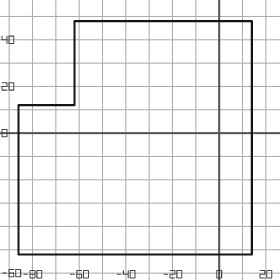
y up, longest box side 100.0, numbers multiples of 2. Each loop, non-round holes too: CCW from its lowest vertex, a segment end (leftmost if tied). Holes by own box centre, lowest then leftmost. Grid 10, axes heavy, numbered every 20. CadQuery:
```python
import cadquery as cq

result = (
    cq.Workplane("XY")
    .moveTo(-86.0, -52.0)
    .lineTo(14.0, -52.0)
    .lineTo(14.0, 48.0)
    .lineTo(-62.0, 48.0)
    .lineTo(-62.0, 12.0)
    .lineTo(-86.0, 12.0)
    .close()
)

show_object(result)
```